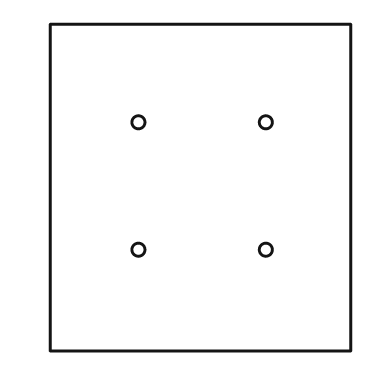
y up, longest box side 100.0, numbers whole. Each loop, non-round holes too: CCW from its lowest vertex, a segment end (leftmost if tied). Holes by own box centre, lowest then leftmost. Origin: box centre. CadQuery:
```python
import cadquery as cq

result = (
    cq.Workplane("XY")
    .moveTo(-46.0, -50.0)
    .lineTo(46.0, -50.0)
    .lineTo(46.0, 50.0)
    .lineTo(-46.0, 50.0)
    .close()
    .moveTo(-19.0, -19.0)
    .circle(2.0)
    .moveTo(20.0, -19.0)
    .circle(2.0)
    .moveTo(-19.0, 20.0)
    .circle(2.0)
    .moveTo(20.0, 20.0)
    .circle(2.0)
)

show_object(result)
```